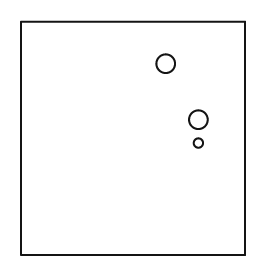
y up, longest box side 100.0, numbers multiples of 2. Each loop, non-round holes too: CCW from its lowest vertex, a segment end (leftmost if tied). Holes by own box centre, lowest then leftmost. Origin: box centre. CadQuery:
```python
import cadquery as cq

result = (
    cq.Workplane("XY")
    .moveTo(-48.0, -50.0)
    .lineTo(48.0, -50.0)
    .lineTo(48.0, 50.0)
    .lineTo(-48.0, 50.0)
    .close()
    .moveTo(28.0, -2.0)
    .circle(2.0)
    .moveTo(28.0, 8.0)
    .circle(4.0)
    .moveTo(14.0, 32.0)
    .circle(4.0)
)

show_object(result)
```